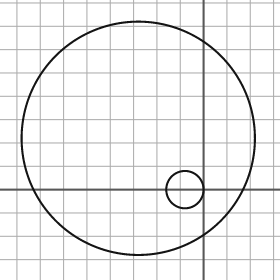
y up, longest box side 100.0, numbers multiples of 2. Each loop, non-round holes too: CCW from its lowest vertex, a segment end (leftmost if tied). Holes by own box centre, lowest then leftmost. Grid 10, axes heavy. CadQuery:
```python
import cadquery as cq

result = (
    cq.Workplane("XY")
    .moveTo(-28.0, 22.0)
    .circle(50.0)
    .moveTo(-8.0, 0.0)
    .circle(8.0)
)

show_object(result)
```